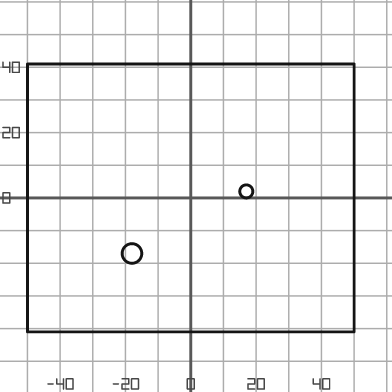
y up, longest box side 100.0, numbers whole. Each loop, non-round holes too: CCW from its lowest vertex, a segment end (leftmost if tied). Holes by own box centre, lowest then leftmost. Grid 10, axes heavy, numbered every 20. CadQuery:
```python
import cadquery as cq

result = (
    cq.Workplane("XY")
    .moveTo(-50.0, -41.0)
    .lineTo(50.0, -41.0)
    .lineTo(50.0, 41.0)
    .lineTo(-50.0, 41.0)
    .close()
    .moveTo(-18.0, -17.0)
    .circle(3.0)
    .moveTo(17.0, 2.0)
    .circle(2.0)
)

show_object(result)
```